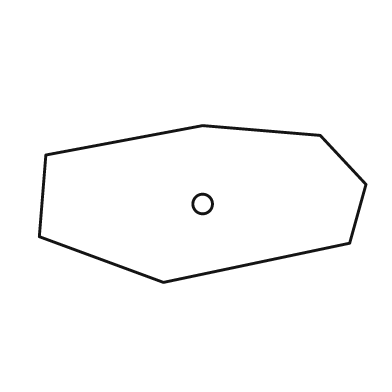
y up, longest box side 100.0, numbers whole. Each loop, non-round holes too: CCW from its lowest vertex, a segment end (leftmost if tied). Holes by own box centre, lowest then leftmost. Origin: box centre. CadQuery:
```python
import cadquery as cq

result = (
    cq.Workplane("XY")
    .moveTo(-12.0, -24.0)
    .lineTo(45.0, -12.0)
    .lineTo(50.0, 6.0)
    .lineTo(36.0, 21.0)
    .lineTo(0.0, 24.0)
    .lineTo(-48.0, 15.0)
    .lineTo(-50.0, -10.0)
    .close()
    .moveTo(0.0, 0.0)
    .circle(3.0)
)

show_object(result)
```